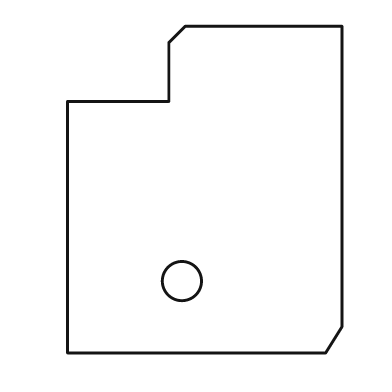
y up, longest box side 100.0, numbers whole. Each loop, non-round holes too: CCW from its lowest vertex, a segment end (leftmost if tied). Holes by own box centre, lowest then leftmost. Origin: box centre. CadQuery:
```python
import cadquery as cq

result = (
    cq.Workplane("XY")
    .moveTo(-42.0, -50.0)
    .lineTo(37.0, -50.0)
    .lineTo(42.0, -42.0)
    .lineTo(42.0, 50.0)
    .lineTo(-6.0, 50.0)
    .lineTo(-11.0, 45.0)
    .lineTo(-11.0, 27.0)
    .lineTo(-42.0, 27.0)
    .close()
    .moveTo(-7.0, -28.0)
    .circle(6.0)
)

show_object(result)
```